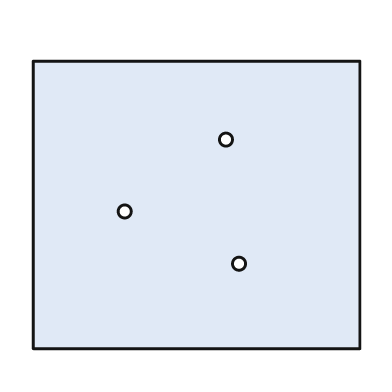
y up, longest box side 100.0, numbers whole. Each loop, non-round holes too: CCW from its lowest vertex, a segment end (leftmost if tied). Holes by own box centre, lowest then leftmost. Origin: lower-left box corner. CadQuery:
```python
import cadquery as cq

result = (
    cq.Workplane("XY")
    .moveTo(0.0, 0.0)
    .lineTo(100.0, 0.0)
    .lineTo(100.0, 88.0)
    .lineTo(0.0, 88.0)
    .close()
    .moveTo(63.0, 26.0)
    .circle(2.0)
    .moveTo(28.0, 42.0)
    .circle(2.0)
    .moveTo(59.0, 64.0)
    .circle(2.0)
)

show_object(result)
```